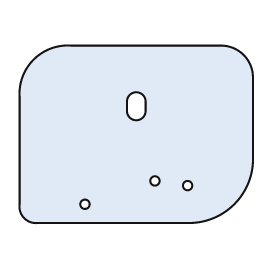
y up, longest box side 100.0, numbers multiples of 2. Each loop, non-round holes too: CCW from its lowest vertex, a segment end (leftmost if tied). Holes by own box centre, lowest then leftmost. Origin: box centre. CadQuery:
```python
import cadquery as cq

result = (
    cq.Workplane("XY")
    .moveTo(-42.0, -38.0)
    .lineTo(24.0, -38.0)
    .threePointArc((42.0, -30.0), (50.0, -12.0))
    .lineTo(50.0, 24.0)
    .threePointArc((46.0, 34.0), (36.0, 38.0))
    .lineTo(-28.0, 38.0)
    .threePointArc((-44.0, 32.0), (-50.0, 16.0))
    .lineTo(-50.0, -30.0)
    .threePointArc((-48.0, -36.0), (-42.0, -38.0))
    .close()
    .moveTo(-22.0, -30.0)
    .circle(2.0)
    .moveTo(22.0, -22.0)
    .circle(2.0)
    .moveTo(8.0, -20.0)
    .circle(2.0)
    .moveTo(-4.0, 10.0)
    .threePointArc((0.0, 6.0), (4.0, 10.0))
    .lineTo(4.0, 14.0)
    .threePointArc((0.0, 18.0), (-4.0, 14.0))
    .close()
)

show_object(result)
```